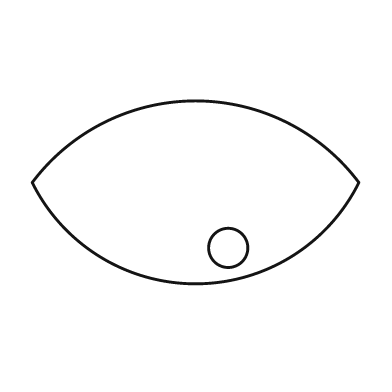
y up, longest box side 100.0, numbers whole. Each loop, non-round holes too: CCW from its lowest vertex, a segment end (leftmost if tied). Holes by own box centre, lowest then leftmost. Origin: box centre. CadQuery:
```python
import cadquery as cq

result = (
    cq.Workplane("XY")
    .moveTo(-50.0, 3.0)
    .threePointArc((0.0, -28.0), (50.0, 3.0))
    .threePointArc((0.0, 28.0), (-50.0, 3.0))
    .close()
    .moveTo(10.0, -17.0)
    .circle(6.0)
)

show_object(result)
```